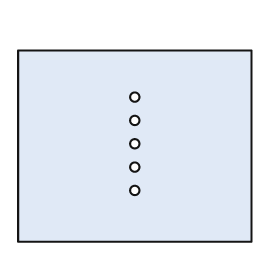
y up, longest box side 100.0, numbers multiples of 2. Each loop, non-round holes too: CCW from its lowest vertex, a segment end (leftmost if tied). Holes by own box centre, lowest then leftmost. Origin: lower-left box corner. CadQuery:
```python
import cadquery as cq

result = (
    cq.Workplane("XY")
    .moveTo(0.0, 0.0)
    .lineTo(100.0, 0.0)
    .lineTo(100.0, 82.0)
    .lineTo(0.0, 82.0)
    .close()
    .moveTo(50.0, 22.0)
    .circle(2.0)
    .moveTo(50.0, 32.0)
    .circle(2.0)
    .moveTo(50.0, 42.0)
    .circle(2.0)
    .moveTo(50.0, 52.0)
    .circle(2.0)
    .moveTo(50.0, 62.0)
    .circle(2.0)
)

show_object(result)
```